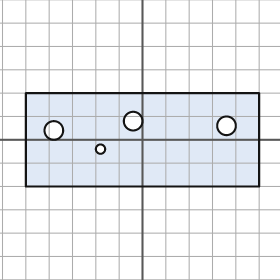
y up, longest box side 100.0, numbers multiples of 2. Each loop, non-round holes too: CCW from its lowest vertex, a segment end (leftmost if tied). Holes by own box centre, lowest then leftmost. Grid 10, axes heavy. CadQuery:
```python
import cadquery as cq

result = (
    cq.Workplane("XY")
    .moveTo(-50.0, -20.0)
    .lineTo(50.0, -20.0)
    .lineTo(50.0, 20.0)
    .lineTo(-50.0, 20.0)
    .close()
    .moveTo(-18.0, -4.0)
    .circle(2.0)
    .moveTo(-38.0, 4.0)
    .circle(4.0)
    .moveTo(36.0, 6.0)
    .circle(4.0)
    .moveTo(-4.0, 8.0)
    .circle(4.0)
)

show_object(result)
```